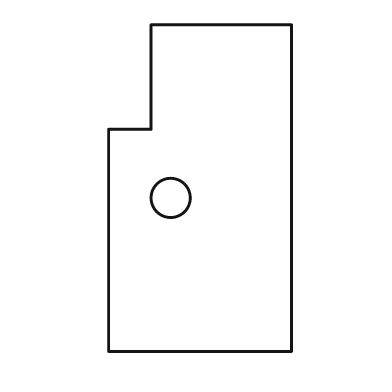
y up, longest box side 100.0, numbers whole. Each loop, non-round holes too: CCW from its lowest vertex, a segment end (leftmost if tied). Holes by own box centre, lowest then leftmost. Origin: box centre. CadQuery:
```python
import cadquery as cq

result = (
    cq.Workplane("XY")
    .moveTo(-28.0, -50.0)
    .lineTo(28.0, -50.0)
    .lineTo(28.0, 50.0)
    .lineTo(-15.0, 50.0)
    .lineTo(-15.0, 18.0)
    .lineTo(-28.0, 18.0)
    .close()
    .moveTo(-9.0, -3.0)
    .circle(6.0)
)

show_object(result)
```